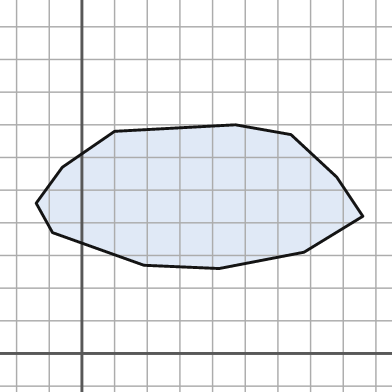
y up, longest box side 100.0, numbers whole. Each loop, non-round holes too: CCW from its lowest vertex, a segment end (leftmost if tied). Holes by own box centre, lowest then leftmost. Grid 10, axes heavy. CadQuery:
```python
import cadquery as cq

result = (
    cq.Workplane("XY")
    .moveTo(42.0, 26.0)
    .lineTo(68.0, 31.0)
    .lineTo(86.0, 42.0)
    .lineTo(78.0, 54.0)
    .lineTo(64.0, 67.0)
    .lineTo(47.0, 70.0)
    .lineTo(10.0, 68.0)
    .lineTo(-6.0, 57.0)
    .lineTo(-14.0, 46.0)
    .lineTo(-9.0, 37.0)
    .lineTo(19.0, 27.0)
    .close()
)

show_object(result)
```